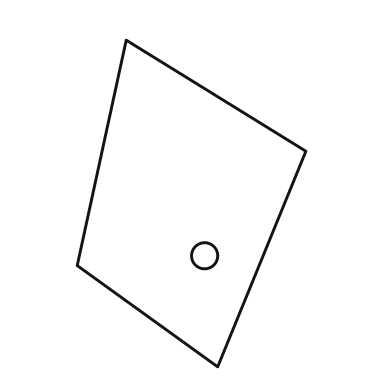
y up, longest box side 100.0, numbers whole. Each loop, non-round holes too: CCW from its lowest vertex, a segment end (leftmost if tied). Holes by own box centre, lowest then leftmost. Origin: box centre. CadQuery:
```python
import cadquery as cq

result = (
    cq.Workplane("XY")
    .moveTo(8.0, -50.0)
    .lineTo(35.0, 16.0)
    .lineTo(-20.0, 50.0)
    .lineTo(-35.0, -19.0)
    .close()
    .moveTo(4.0, -16.0)
    .circle(4.0)
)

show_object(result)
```